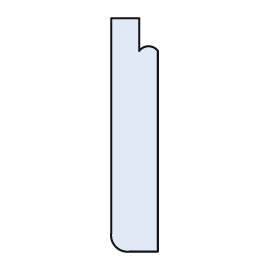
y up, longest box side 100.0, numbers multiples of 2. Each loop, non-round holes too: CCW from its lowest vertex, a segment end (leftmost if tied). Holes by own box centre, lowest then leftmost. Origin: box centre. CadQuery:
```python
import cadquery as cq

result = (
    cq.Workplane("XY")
    .moveTo(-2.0, -50.0)
    .lineTo(10.0, -50.0)
    .lineTo(10.0, 36.0)
    .threePointArc((6.0, 38.0), (2.0, 36.0))
    .lineTo(2.0, 50.0)
    .lineTo(-10.0, 50.0)
    .lineTo(-10.0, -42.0)
    .threePointArc((-8.0, -48.0), (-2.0, -50.0))
    .close()
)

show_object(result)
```